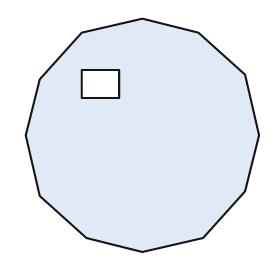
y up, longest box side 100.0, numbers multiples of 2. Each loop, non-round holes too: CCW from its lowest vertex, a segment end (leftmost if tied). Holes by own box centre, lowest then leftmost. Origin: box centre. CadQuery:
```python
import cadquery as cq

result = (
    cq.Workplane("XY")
    .moveTo(0.0, -50.0)
    .lineTo(26.0, -44.0)
    .lineTo(44.0, -24.0)
    .lineTo(50.0, 0.0)
    .lineTo(44.0, 26.0)
    .lineTo(24.0, 44.0)
    .lineTo(0.0, 50.0)
    .lineTo(-26.0, 44.0)
    .lineTo(-44.0, 24.0)
    .lineTo(-50.0, 0.0)
    .lineTo(-44.0, -26.0)
    .lineTo(-24.0, -44.0)
    .close()
    .moveTo(-26.0, 16.0)
    .lineTo(-10.0, 16.0)
    .lineTo(-10.0, 28.0)
    .lineTo(-26.0, 28.0)
    .close()
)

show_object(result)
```